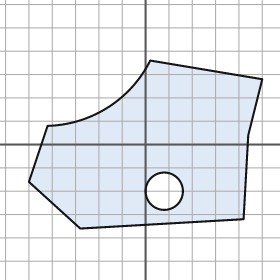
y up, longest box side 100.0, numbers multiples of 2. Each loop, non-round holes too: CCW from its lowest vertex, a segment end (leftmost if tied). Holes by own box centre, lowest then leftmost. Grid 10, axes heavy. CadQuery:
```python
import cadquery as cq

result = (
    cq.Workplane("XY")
    .moveTo(-28.0, -36.0)
    .lineTo(42.0, -32.0)
    .lineTo(44.0, 4.0)
    .lineTo(50.0, 28.0)
    .lineTo(2.0, 36.0)
    .threePointArc((-16.0, 16.0), (-42.0, 8.0))
    .lineTo(-50.0, -16.0)
    .close()
    .moveTo(8.0, -20.0)
    .circle(8.0)
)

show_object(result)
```